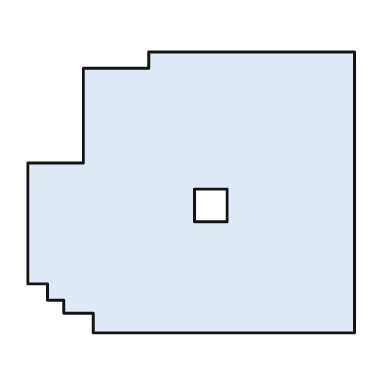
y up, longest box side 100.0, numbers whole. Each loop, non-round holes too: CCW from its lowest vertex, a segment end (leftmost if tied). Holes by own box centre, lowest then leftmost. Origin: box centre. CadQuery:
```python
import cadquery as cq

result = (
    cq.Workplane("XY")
    .moveTo(-30.0, -43.0)
    .lineTo(50.0, -43.0)
    .lineTo(50.0, 43.0)
    .lineTo(-13.0, 43.0)
    .lineTo(-13.0, 38.0)
    .lineTo(-33.0, 38.0)
    .lineTo(-33.0, 9.0)
    .lineTo(-50.0, 9.0)
    .lineTo(-50.0, -28.0)
    .lineTo(-44.0, -28.0)
    .lineTo(-44.0, -33.0)
    .lineTo(-39.0, -33.0)
    .lineTo(-39.0, -37.0)
    .lineTo(-30.0, -37.0)
    .close()
    .moveTo(1.0, -9.0)
    .lineTo(11.0, -9.0)
    .lineTo(11.0, 1.0)
    .lineTo(1.0, 1.0)
    .close()
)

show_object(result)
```